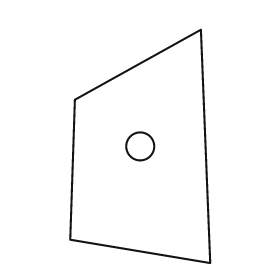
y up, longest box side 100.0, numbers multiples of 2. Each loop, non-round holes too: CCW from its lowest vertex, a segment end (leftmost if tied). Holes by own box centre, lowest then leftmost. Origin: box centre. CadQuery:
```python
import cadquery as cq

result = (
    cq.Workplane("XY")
    .moveTo(30.0, -50.0)
    .lineTo(26.0, 50.0)
    .lineTo(-28.0, 20.0)
    .lineTo(-30.0, -40.0)
    .close()
    .moveTo(0.0, 0.0)
    .circle(6.0)
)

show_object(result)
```